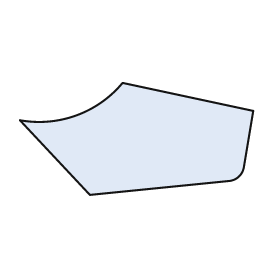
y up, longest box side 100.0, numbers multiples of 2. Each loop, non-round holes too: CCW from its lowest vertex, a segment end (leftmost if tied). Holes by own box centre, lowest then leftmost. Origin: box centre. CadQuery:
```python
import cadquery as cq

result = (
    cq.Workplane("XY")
    .moveTo(-20.0, -24.0)
    .lineTo(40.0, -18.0)
    .threePointArc((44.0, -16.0), (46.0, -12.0))
    .lineTo(50.0, 12.0)
    .lineTo(-6.0, 24.0)
    .threePointArc((-26.0, 10.0), (-50.0, 8.0))
    .close()
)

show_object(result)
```